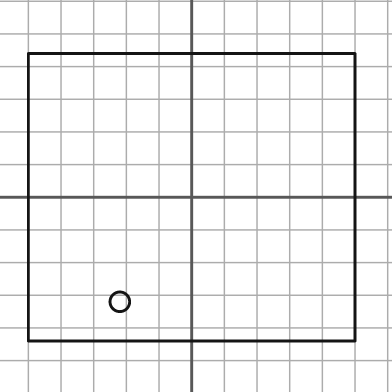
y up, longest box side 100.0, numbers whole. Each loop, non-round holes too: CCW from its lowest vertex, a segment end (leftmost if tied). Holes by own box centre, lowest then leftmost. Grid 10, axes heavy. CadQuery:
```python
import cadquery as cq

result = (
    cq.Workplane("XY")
    .moveTo(-50.0, -44.0)
    .lineTo(50.0, -44.0)
    .lineTo(50.0, 44.0)
    .lineTo(-50.0, 44.0)
    .close()
    .moveTo(-22.0, -32.0)
    .circle(3.0)
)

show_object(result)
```